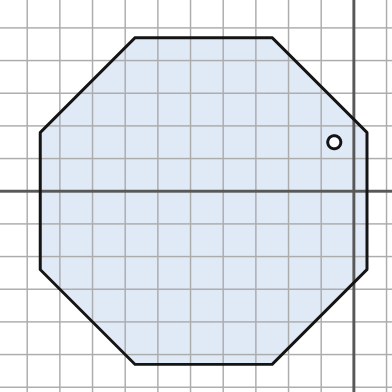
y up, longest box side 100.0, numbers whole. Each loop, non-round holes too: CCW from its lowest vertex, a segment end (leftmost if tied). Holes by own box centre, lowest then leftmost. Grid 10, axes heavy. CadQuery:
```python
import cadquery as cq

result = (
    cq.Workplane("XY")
    .moveTo(-67.0, -53.0)
    .lineTo(-25.0, -53.0)
    .lineTo(4.0, -24.0)
    .lineTo(4.0, 18.0)
    .lineTo(-25.0, 47.0)
    .lineTo(-67.0, 47.0)
    .lineTo(-96.0, 18.0)
    .lineTo(-96.0, -24.0)
    .close()
    .moveTo(-6.0, 15.0)
    .circle(2.0)
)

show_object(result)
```